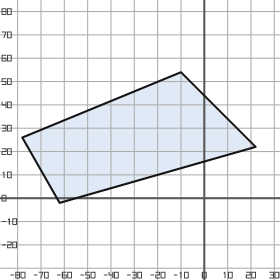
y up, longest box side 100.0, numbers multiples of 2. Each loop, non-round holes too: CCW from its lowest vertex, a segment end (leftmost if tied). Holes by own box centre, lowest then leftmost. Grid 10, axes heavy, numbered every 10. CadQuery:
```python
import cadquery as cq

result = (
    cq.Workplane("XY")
    .moveTo(-62.0, -2.0)
    .lineTo(22.0, 22.0)
    .lineTo(-10.0, 54.0)
    .lineTo(-78.0, 26.0)
    .close()
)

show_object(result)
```